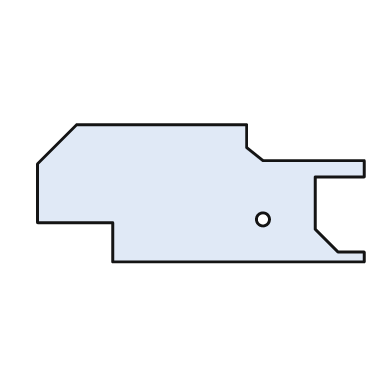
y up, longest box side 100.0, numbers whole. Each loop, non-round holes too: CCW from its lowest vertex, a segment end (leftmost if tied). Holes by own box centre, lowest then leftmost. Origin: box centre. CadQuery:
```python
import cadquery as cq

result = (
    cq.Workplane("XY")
    .moveTo(-27.0, -21.0)
    .lineTo(50.0, -21.0)
    .lineTo(50.0, -18.0)
    .lineTo(42.0, -18.0)
    .lineTo(35.0, -11.0)
    .lineTo(35.0, 5.0)
    .lineTo(50.0, 5.0)
    .lineTo(50.0, 10.0)
    .lineTo(19.0, 10.0)
    .lineTo(14.0, 14.0)
    .lineTo(14.0, 21.0)
    .lineTo(-38.0, 21.0)
    .lineTo(-50.0, 9.0)
    .lineTo(-50.0, -9.0)
    .lineTo(-27.0, -9.0)
    .close()
    .moveTo(19.0, -8.0)
    .circle(2.0)
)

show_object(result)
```